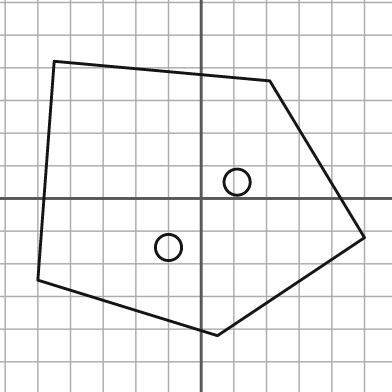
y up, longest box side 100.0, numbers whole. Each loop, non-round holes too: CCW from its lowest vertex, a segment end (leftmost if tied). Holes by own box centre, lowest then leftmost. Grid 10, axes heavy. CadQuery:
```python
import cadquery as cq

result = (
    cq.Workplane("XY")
    .moveTo(5.0, -42.0)
    .lineTo(50.0, -12.0)
    .lineTo(21.0, 36.0)
    .lineTo(-45.0, 42.0)
    .lineTo(-50.0, -25.0)
    .close()
    .moveTo(-10.0, -15.0)
    .circle(4.0)
    .moveTo(11.0, 5.0)
    .circle(4.0)
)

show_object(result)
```